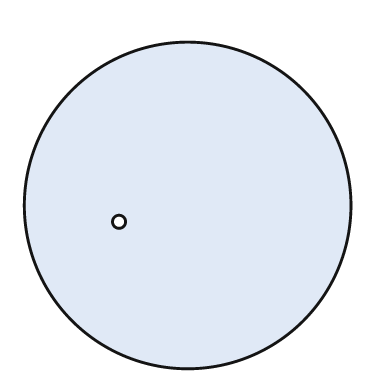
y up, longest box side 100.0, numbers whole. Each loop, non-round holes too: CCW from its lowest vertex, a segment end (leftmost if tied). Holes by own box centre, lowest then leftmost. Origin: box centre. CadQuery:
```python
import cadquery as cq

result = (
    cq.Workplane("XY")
    .moveTo(0.0, 0.0)
    .circle(50.0)
    .moveTo(-21.0, -5.0)
    .circle(2.0)
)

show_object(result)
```